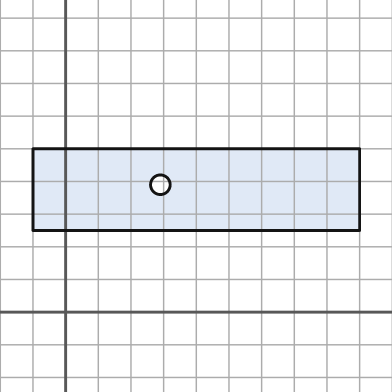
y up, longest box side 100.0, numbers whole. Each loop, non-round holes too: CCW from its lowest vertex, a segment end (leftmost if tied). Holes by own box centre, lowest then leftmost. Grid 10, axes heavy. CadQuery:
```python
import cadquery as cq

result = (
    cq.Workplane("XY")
    .moveTo(-10.0, 25.0)
    .lineTo(90.0, 25.0)
    .lineTo(90.0, 50.0)
    .lineTo(-10.0, 50.0)
    .close()
    .moveTo(29.0, 39.0)
    .circle(3.0)
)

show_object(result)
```